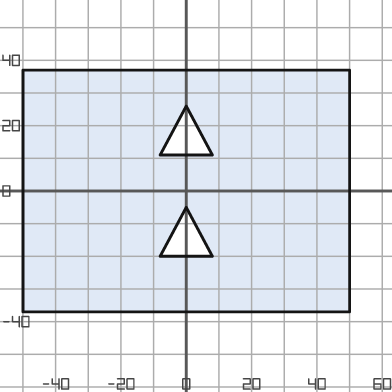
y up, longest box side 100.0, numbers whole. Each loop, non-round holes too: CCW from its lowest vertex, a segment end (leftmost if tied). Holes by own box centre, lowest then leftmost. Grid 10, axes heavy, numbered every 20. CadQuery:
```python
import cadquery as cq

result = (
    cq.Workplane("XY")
    .moveTo(-50.0, -37.0)
    .lineTo(50.0, -37.0)
    .lineTo(50.0, 37.0)
    .lineTo(-50.0, 37.0)
    .close()
    .moveTo(-8.0, -20.0)
    .lineTo(8.0, -20.0)
    .lineTo(0.0, -5.0)
    .close()
    .moveTo(-8.0, 11.0)
    .lineTo(8.0, 11.0)
    .lineTo(0.0, 26.0)
    .close()
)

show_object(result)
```